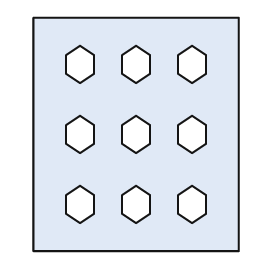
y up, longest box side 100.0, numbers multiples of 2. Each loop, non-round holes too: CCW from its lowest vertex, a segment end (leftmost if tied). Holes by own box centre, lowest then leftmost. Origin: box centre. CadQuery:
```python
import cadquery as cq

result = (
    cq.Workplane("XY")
    .moveTo(-44.0, -50.0)
    .lineTo(44.0, -50.0)
    .lineTo(44.0, 50.0)
    .lineTo(-44.0, 50.0)
    .close()
    .moveTo(-24.0, -38.0)
    .lineTo(-18.0, -34.0)
    .lineTo(-18.0, -26.0)
    .lineTo(-24.0, -22.0)
    .lineTo(-30.0, -26.0)
    .lineTo(-30.0, -34.0)
    .close()
    .moveTo(0.0, -38.0)
    .lineTo(6.0, -34.0)
    .lineTo(6.0, -26.0)
    .lineTo(0.0, -22.0)
    .lineTo(-6.0, -26.0)
    .lineTo(-6.0, -34.0)
    .close()
    .moveTo(24.0, -38.0)
    .lineTo(30.0, -34.0)
    .lineTo(30.0, -26.0)
    .lineTo(24.0, -22.0)
    .lineTo(18.0, -26.0)
    .lineTo(18.0, -34.0)
    .close()
    .moveTo(-24.0, -8.0)
    .lineTo(-18.0, -4.0)
    .lineTo(-18.0, 4.0)
    .lineTo(-24.0, 8.0)
    .lineTo(-30.0, 4.0)
    .lineTo(-30.0, -4.0)
    .close()
    .moveTo(0.0, -8.0)
    .lineTo(6.0, -4.0)
    .lineTo(6.0, 4.0)
    .lineTo(0.0, 8.0)
    .lineTo(-6.0, 4.0)
    .lineTo(-6.0, -4.0)
    .close()
    .moveTo(24.0, -8.0)
    .lineTo(30.0, -4.0)
    .lineTo(30.0, 4.0)
    .lineTo(24.0, 8.0)
    .lineTo(18.0, 4.0)
    .lineTo(18.0, -4.0)
    .close()
    .moveTo(-24.0, 22.0)
    .lineTo(-18.0, 26.0)
    .lineTo(-18.0, 34.0)
    .lineTo(-24.0, 38.0)
    .lineTo(-30.0, 34.0)
    .lineTo(-30.0, 26.0)
    .close()
    .moveTo(0.0, 22.0)
    .lineTo(6.0, 26.0)
    .lineTo(6.0, 34.0)
    .lineTo(0.0, 38.0)
    .lineTo(-6.0, 34.0)
    .lineTo(-6.0, 26.0)
    .close()
    .moveTo(24.0, 22.0)
    .lineTo(30.0, 26.0)
    .lineTo(30.0, 34.0)
    .lineTo(24.0, 38.0)
    .lineTo(18.0, 34.0)
    .lineTo(18.0, 26.0)
    .close()
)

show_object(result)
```